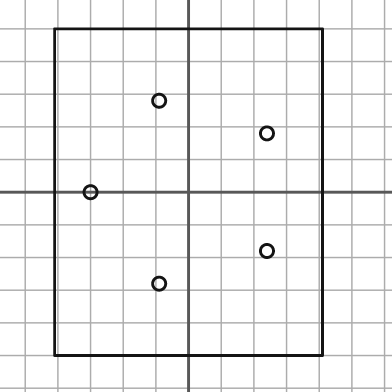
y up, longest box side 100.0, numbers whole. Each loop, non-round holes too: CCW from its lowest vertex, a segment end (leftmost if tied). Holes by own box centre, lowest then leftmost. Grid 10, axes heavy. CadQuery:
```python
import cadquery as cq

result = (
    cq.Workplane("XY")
    .moveTo(-41.0, -50.0)
    .lineTo(41.0, -50.0)
    .lineTo(41.0, 50.0)
    .lineTo(-41.0, 50.0)
    .close()
    .moveTo(-9.0, -28.0)
    .circle(2.0)
    .moveTo(24.0, -18.0)
    .circle(2.0)
    .moveTo(-30.0, 0.0)
    .circle(2.0)
    .moveTo(24.0, 18.0)
    .circle(2.0)
    .moveTo(-9.0, 28.0)
    .circle(2.0)
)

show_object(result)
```